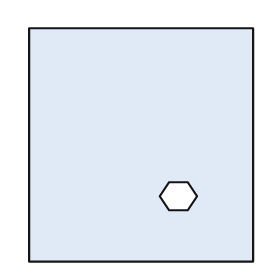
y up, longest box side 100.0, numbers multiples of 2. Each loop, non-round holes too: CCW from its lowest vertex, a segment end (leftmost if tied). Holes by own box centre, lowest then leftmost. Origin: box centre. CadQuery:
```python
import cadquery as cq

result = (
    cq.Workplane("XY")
    .moveTo(-48.0, -50.0)
    .lineTo(48.0, -50.0)
    .lineTo(48.0, 50.0)
    .lineTo(-48.0, 50.0)
    .close()
    .moveTo(12.0, -28.0)
    .lineTo(20.0, -28.0)
    .lineTo(24.0, -22.0)
    .lineTo(20.0, -16.0)
    .lineTo(12.0, -16.0)
    .lineTo(8.0, -22.0)
    .close()
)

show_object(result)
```